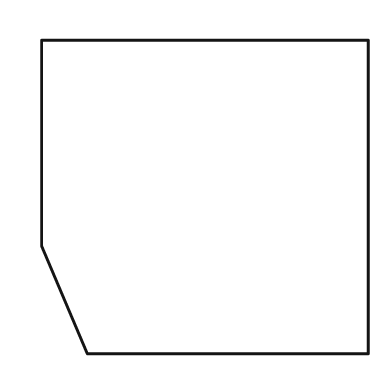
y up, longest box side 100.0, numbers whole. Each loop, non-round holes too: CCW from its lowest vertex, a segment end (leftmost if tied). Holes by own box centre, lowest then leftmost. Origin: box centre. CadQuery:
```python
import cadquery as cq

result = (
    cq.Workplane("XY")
    .moveTo(-36.0, -48.0)
    .lineTo(50.0, -48.0)
    .lineTo(50.0, 48.0)
    .lineTo(-50.0, 48.0)
    .lineTo(-50.0, -15.0)
    .close()
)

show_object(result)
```